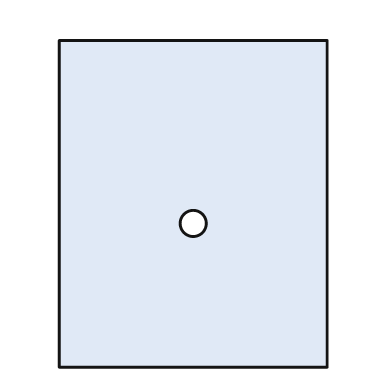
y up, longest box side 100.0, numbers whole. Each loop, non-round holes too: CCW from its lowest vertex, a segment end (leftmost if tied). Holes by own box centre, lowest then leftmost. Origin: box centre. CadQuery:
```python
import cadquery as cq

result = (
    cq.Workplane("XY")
    .moveTo(-41.0, -50.0)
    .lineTo(41.0, -50.0)
    .lineTo(41.0, 50.0)
    .lineTo(-41.0, 50.0)
    .close()
    .moveTo(0.0, -6.0)
    .circle(4.0)
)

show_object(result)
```